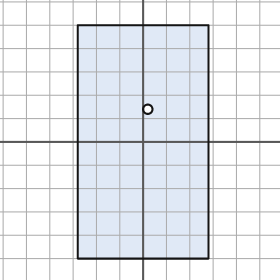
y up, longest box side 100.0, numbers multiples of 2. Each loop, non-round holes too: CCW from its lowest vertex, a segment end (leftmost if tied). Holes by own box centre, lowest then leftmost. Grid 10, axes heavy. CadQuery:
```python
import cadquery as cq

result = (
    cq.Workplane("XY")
    .moveTo(-28.0, -50.0)
    .lineTo(28.0, -50.0)
    .lineTo(28.0, 50.0)
    .lineTo(-28.0, 50.0)
    .close()
    .moveTo(2.0, 14.0)
    .circle(2.0)
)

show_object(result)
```